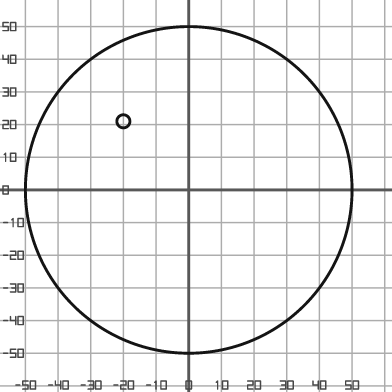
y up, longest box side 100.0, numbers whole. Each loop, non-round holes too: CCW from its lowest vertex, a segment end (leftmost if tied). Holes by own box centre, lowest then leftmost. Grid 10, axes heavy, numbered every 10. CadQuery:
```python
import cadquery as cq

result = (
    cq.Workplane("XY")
    .moveTo(0.0, 0.0)
    .circle(50.0)
    .moveTo(-20.0, 21.0)
    .circle(2.0)
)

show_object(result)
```